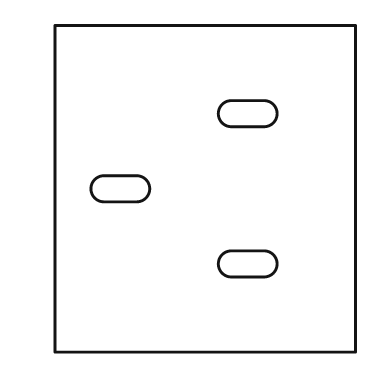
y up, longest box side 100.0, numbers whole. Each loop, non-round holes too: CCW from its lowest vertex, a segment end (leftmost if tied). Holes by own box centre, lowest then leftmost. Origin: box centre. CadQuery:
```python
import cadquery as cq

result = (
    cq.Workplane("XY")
    .moveTo(-46.0, -50.0)
    .lineTo(46.0, -50.0)
    .lineTo(46.0, 50.0)
    .lineTo(-46.0, 50.0)
    .close()
    .moveTo(8.0, -27.0)
    .lineTo(18.0, -27.0)
    .threePointArc((22.0, -23.0), (18.0, -19.0))
    .lineTo(8.0, -19.0)
    .threePointArc((4.0, -23.0), (8.0, -27.0))
    .close()
    .moveTo(-31.0, -4.0)
    .lineTo(-21.0, -4.0)
    .threePointArc((-17.0, 0.0), (-21.0, 4.0))
    .lineTo(-31.0, 4.0)
    .threePointArc((-35.0, 0.0), (-31.0, -4.0))
    .close()
    .moveTo(8.0, 19.0)
    .lineTo(18.0, 19.0)
    .threePointArc((22.0, 23.0), (18.0, 27.0))
    .lineTo(8.0, 27.0)
    .threePointArc((4.0, 23.0), (8.0, 19.0))
    .close()
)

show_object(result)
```